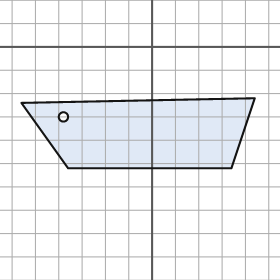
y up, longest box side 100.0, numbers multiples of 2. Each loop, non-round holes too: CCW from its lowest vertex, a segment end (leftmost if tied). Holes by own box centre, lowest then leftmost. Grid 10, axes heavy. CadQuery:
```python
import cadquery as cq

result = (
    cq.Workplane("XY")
    .moveTo(-36.0, -52.0)
    .lineTo(34.0, -52.0)
    .lineTo(44.0, -22.0)
    .lineTo(-56.0, -24.0)
    .close()
    .moveTo(-38.0, -30.0)
    .circle(2.0)
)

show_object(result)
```